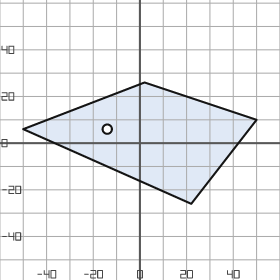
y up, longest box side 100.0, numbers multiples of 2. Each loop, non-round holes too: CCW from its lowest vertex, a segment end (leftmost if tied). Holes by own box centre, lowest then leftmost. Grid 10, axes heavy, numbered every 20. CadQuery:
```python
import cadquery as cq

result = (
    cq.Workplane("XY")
    .moveTo(22.0, -26.0)
    .lineTo(50.0, 10.0)
    .lineTo(2.0, 26.0)
    .lineTo(-50.0, 6.0)
    .close()
    .moveTo(-14.0, 6.0)
    .circle(2.0)
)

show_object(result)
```